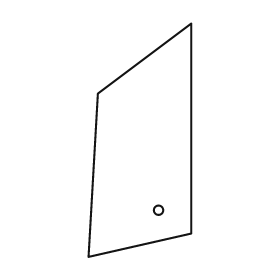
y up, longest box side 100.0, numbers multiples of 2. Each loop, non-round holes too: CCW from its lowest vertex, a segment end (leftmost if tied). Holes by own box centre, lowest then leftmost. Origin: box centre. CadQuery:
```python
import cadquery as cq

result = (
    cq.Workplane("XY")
    .moveTo(-22.0, -50.0)
    .lineTo(22.0, -40.0)
    .lineTo(22.0, 50.0)
    .lineTo(-18.0, 20.0)
    .close()
    .moveTo(8.0, -30.0)
    .circle(2.0)
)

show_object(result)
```